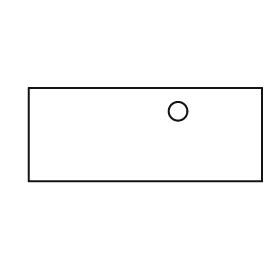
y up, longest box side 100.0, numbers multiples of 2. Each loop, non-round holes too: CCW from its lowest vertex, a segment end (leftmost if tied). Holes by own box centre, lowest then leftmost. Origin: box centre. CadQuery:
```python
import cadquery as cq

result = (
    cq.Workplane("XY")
    .moveTo(-50.0, -20.0)
    .lineTo(50.0, -20.0)
    .lineTo(50.0, 20.0)
    .lineTo(-50.0, 20.0)
    .close()
    .moveTo(14.0, 10.0)
    .circle(4.0)
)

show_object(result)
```